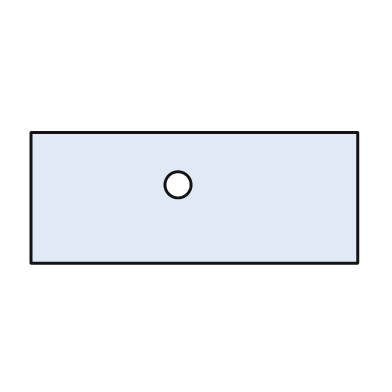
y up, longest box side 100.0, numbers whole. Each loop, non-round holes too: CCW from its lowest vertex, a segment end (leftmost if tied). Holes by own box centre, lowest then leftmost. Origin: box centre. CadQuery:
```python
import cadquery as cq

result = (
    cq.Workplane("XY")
    .moveTo(-50.0, -20.0)
    .lineTo(50.0, -20.0)
    .lineTo(50.0, 20.0)
    .lineTo(-50.0, 20.0)
    .close()
    .moveTo(-5.0, 4.0)
    .circle(4.0)
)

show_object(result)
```